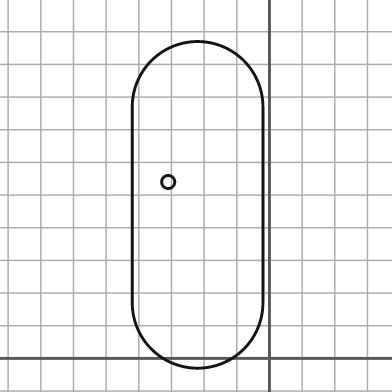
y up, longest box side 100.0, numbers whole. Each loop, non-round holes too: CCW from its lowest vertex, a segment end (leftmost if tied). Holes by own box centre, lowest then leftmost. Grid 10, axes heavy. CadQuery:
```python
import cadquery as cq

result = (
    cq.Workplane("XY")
    .moveTo(-42.0, 17.0)
    .threePointArc((-22.0, -3.0), (-2.0, 17.0))
    .lineTo(-2.0, 77.0)
    .threePointArc((-22.0, 97.0), (-42.0, 77.0))
    .close()
    .moveTo(-31.0, 54.0)
    .circle(2.0)
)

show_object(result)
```